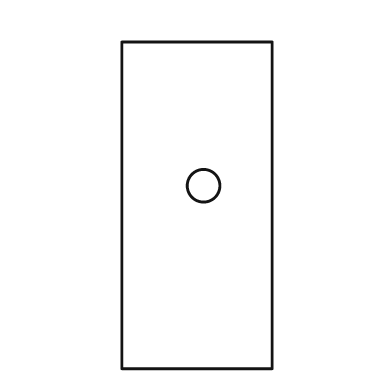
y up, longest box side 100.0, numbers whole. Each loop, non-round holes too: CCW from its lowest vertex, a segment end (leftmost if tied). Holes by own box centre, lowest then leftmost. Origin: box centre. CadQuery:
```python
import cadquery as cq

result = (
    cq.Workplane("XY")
    .moveTo(-23.0, -50.0)
    .lineTo(23.0, -50.0)
    .lineTo(23.0, 50.0)
    .lineTo(-23.0, 50.0)
    .close()
    .moveTo(2.0, 6.0)
    .circle(5.0)
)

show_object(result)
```